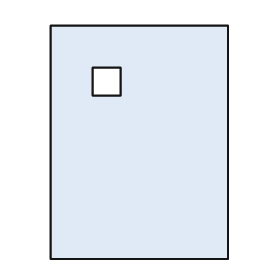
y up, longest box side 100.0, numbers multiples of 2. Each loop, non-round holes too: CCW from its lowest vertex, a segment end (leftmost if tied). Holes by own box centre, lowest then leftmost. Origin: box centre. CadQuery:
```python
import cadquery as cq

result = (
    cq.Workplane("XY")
    .moveTo(-38.0, -50.0)
    .lineTo(38.0, -50.0)
    .lineTo(38.0, 50.0)
    .lineTo(-38.0, 50.0)
    .close()
    .moveTo(-20.0, 20.0)
    .lineTo(-8.0, 20.0)
    .lineTo(-8.0, 32.0)
    .lineTo(-20.0, 32.0)
    .close()
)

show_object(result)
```